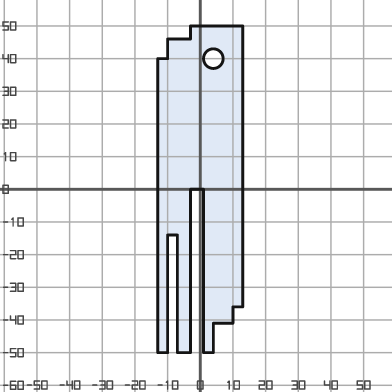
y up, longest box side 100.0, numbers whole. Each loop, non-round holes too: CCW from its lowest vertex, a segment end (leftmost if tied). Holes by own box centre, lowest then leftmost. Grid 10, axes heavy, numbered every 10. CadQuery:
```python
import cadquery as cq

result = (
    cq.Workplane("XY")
    .moveTo(-13.0, -50.0)
    .lineTo(-10.0, -50.0)
    .lineTo(-10.0, -14.0)
    .lineTo(-7.0, -14.0)
    .lineTo(-7.0, -50.0)
    .lineTo(-3.0, -50.0)
    .lineTo(-3.0, 0.0)
    .lineTo(1.0, 0.0)
    .lineTo(1.0, -50.0)
    .lineTo(4.0, -50.0)
    .lineTo(4.0, -41.0)
    .lineTo(10.0, -41.0)
    .lineTo(10.0, -36.0)
    .lineTo(13.0, -36.0)
    .lineTo(13.0, 50.0)
    .lineTo(-3.0, 50.0)
    .lineTo(-3.0, 46.0)
    .lineTo(-10.0, 46.0)
    .lineTo(-10.0, 40.0)
    .lineTo(-13.0, 40.0)
    .close()
    .moveTo(4.0, 40.0)
    .circle(3.0)
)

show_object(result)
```